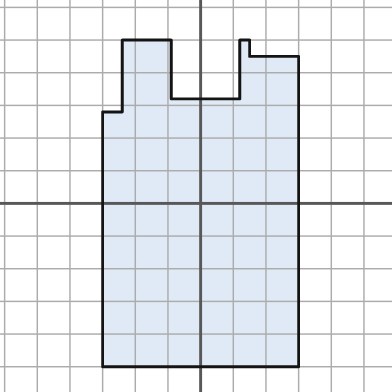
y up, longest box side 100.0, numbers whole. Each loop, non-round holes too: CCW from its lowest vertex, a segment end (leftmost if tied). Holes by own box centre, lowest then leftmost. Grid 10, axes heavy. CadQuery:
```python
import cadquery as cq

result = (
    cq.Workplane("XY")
    .moveTo(-30.0, -50.0)
    .lineTo(30.0, -50.0)
    .lineTo(30.0, 45.0)
    .lineTo(15.0, 45.0)
    .lineTo(15.0, 50.0)
    .lineTo(12.0, 50.0)
    .lineTo(12.0, 32.0)
    .lineTo(-9.0, 32.0)
    .lineTo(-9.0, 50.0)
    .lineTo(-24.0, 50.0)
    .lineTo(-24.0, 28.0)
    .lineTo(-30.0, 28.0)
    .close()
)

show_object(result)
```